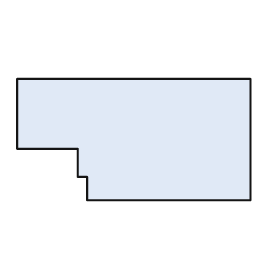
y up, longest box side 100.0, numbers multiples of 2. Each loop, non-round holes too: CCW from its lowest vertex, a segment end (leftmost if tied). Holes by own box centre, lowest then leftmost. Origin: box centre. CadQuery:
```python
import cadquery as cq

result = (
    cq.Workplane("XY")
    .moveTo(-20.0, -26.0)
    .lineTo(50.0, -26.0)
    .lineTo(50.0, 26.0)
    .lineTo(-50.0, 26.0)
    .lineTo(-50.0, -4.0)
    .lineTo(-24.0, -4.0)
    .lineTo(-24.0, -16.0)
    .lineTo(-20.0, -16.0)
    .close()
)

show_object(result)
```